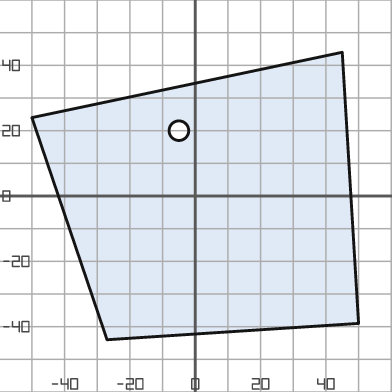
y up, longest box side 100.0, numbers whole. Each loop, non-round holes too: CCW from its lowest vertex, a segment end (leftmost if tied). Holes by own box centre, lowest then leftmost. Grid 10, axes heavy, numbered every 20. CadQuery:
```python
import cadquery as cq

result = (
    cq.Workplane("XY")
    .moveTo(-27.0, -44.0)
    .lineTo(50.0, -39.0)
    .lineTo(45.0, 44.0)
    .lineTo(-50.0, 24.0)
    .close()
    .moveTo(-5.0, 20.0)
    .circle(3.0)
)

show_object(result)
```